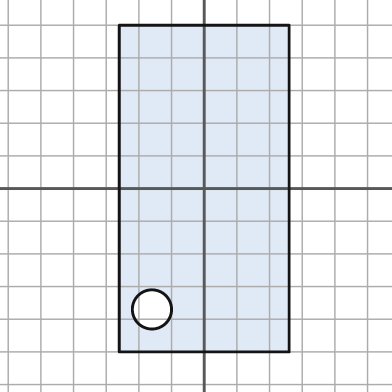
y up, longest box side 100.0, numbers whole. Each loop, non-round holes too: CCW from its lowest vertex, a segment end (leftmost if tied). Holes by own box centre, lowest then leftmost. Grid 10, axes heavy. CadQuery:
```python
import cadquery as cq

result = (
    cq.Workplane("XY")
    .moveTo(-26.0, -50.0)
    .lineTo(26.0, -50.0)
    .lineTo(26.0, 50.0)
    .lineTo(-26.0, 50.0)
    .close()
    .moveTo(-16.0, -37.0)
    .circle(6.0)
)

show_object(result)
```